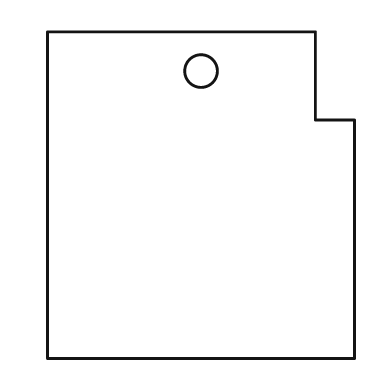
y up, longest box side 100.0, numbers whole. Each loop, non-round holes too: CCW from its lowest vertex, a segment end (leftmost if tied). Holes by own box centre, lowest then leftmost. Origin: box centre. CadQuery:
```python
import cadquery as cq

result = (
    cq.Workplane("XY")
    .moveTo(-47.0, -50.0)
    .lineTo(47.0, -50.0)
    .lineTo(47.0, 23.0)
    .lineTo(35.0, 23.0)
    .lineTo(35.0, 50.0)
    .lineTo(-47.0, 50.0)
    .close()
    .moveTo(0.0, 38.0)
    .circle(5.0)
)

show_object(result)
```